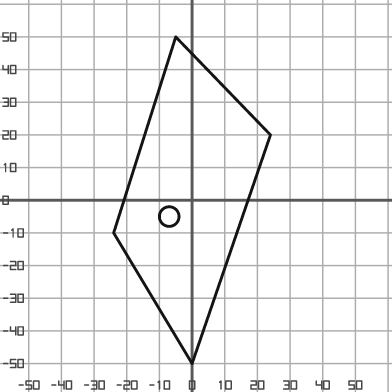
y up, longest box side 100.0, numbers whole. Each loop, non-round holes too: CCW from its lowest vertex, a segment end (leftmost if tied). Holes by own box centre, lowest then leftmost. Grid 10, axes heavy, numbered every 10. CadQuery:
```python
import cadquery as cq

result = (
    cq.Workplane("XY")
    .moveTo(0.0, -50.0)
    .lineTo(24.0, 20.0)
    .lineTo(-5.0, 50.0)
    .lineTo(-24.0, -10.0)
    .close()
    .moveTo(-7.0, -5.0)
    .circle(3.0)
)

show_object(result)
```